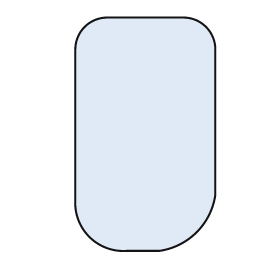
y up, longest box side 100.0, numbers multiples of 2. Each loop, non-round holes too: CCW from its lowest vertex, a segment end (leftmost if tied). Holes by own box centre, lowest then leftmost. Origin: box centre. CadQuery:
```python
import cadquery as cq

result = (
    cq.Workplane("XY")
    .moveTo(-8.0, -50.0)
    .lineTo(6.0, -50.0)
    .threePointArc((22.0, -42.0), (30.0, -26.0))
    .lineTo(30.0, 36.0)
    .threePointArc((26.0, 46.0), (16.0, 50.0))
    .lineTo(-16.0, 50.0)
    .threePointArc((-26.0, 46.0), (-30.0, 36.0))
    .lineTo(-30.0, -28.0)
    .threePointArc((-24.0, -44.0), (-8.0, -50.0))
    .close()
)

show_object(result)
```